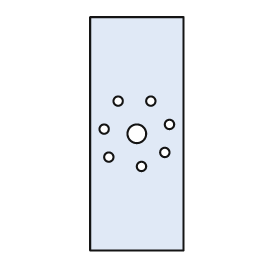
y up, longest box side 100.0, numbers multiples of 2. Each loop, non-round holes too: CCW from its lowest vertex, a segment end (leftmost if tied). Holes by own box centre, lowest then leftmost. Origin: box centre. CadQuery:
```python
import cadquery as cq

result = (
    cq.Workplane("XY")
    .moveTo(-20.0, -50.0)
    .lineTo(20.0, -50.0)
    .lineTo(20.0, 50.0)
    .lineTo(-20.0, 50.0)
    .close()
    .moveTo(2.0, -14.0)
    .circle(2.0)
    .moveTo(-12.0, -10.0)
    .circle(2.0)
    .moveTo(12.0, -8.0)
    .circle(2.0)
    .moveTo(0.0, 0.0)
    .circle(4.0)
    .moveTo(-14.0, 2.0)
    .circle(2.0)
    .moveTo(14.0, 4.0)
    .circle(2.0)
    .moveTo(-8.0, 14.0)
    .circle(2.0)
    .moveTo(6.0, 14.0)
    .circle(2.0)
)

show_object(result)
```